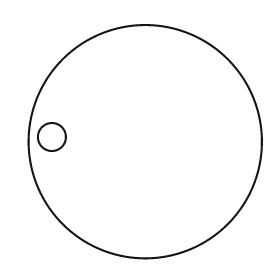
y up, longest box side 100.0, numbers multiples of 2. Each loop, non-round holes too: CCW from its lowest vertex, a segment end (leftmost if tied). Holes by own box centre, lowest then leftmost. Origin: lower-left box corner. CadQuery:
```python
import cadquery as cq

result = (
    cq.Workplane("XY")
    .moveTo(50.0, 50.0)
    .circle(50.0)
    .moveTo(10.0, 52.0)
    .circle(6.0)
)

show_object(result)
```